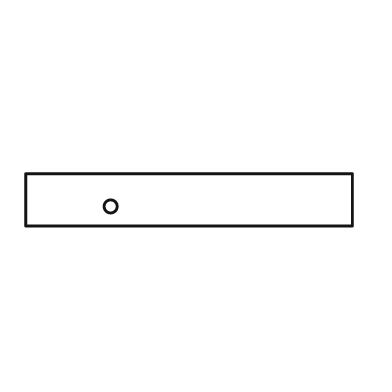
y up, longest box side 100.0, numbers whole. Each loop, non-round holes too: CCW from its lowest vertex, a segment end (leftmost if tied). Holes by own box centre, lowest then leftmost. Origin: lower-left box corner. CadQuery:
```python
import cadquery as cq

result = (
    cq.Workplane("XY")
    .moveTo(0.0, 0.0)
    .lineTo(100.0, 0.0)
    .lineTo(100.0, 16.0)
    .lineTo(0.0, 16.0)
    .close()
    .moveTo(26.0, 6.0)
    .circle(2.0)
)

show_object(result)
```